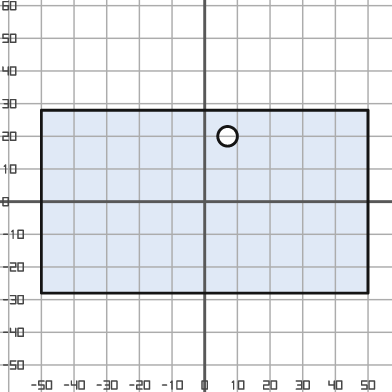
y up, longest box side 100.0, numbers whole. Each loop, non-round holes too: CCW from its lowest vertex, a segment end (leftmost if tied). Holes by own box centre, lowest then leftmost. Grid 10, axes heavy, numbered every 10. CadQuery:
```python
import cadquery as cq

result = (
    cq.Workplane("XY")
    .moveTo(-50.0, -28.0)
    .lineTo(50.0, -28.0)
    .lineTo(50.0, 28.0)
    .lineTo(-50.0, 28.0)
    .close()
    .moveTo(7.0, 20.0)
    .circle(3.0)
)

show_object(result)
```